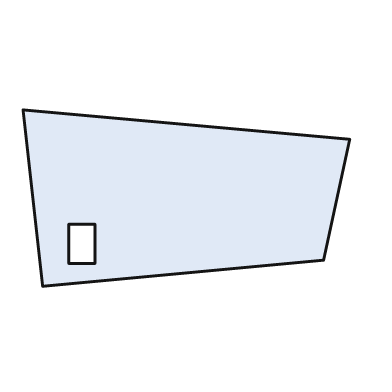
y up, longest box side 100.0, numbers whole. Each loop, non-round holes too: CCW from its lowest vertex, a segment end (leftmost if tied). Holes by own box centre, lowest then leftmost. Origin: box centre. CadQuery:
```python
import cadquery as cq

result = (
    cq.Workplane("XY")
    .moveTo(-44.0, -27.0)
    .lineTo(42.0, -19.0)
    .lineTo(50.0, 18.0)
    .lineTo(-50.0, 27.0)
    .close()
    .moveTo(-36.0, -20.0)
    .lineTo(-28.0, -20.0)
    .lineTo(-28.0, -8.0)
    .lineTo(-36.0, -8.0)
    .close()
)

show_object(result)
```